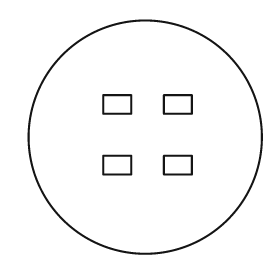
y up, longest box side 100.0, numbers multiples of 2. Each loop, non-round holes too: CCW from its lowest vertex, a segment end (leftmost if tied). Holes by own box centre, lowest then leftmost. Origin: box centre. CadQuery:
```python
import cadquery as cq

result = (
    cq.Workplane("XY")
    .moveTo(0.0, 0.0)
    .circle(50.0)
    .moveTo(-18.0, -16.0)
    .lineTo(-6.0, -16.0)
    .lineTo(-6.0, -8.0)
    .lineTo(-18.0, -8.0)
    .close()
    .moveTo(8.0, -16.0)
    .lineTo(20.0, -16.0)
    .lineTo(20.0, -8.0)
    .lineTo(8.0, -8.0)
    .close()
    .moveTo(-18.0, 10.0)
    .lineTo(-6.0, 10.0)
    .lineTo(-6.0, 18.0)
    .lineTo(-18.0, 18.0)
    .close()
    .moveTo(8.0, 10.0)
    .lineTo(20.0, 10.0)
    .lineTo(20.0, 18.0)
    .lineTo(8.0, 18.0)
    .close()
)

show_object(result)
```